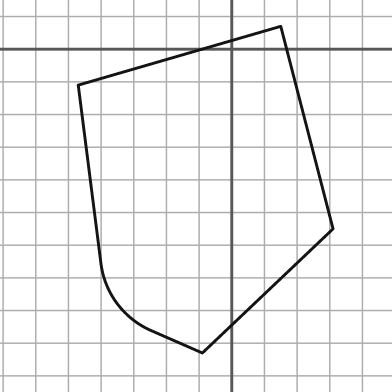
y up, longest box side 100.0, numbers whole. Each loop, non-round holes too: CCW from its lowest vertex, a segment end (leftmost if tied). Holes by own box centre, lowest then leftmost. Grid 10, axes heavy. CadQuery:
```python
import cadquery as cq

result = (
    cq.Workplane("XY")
    .moveTo(-9.0, -93.0)
    .lineTo(31.0, -55.0)
    .lineTo(15.0, 7.0)
    .lineTo(-47.0, -11.0)
    .lineTo(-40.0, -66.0)
    .threePointArc((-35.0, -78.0), (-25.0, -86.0))
    .close()
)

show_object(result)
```